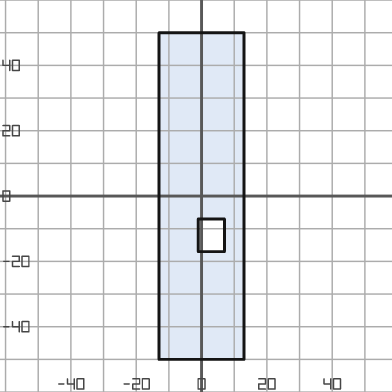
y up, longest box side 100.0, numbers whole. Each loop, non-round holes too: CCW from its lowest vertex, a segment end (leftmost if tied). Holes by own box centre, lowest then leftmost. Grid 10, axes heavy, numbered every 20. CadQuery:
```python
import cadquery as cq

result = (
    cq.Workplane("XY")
    .moveTo(-13.0, -50.0)
    .lineTo(13.0, -50.0)
    .lineTo(13.0, 50.0)
    .lineTo(-13.0, 50.0)
    .close()
    .moveTo(-1.0, -17.0)
    .lineTo(7.0, -17.0)
    .lineTo(7.0, -7.0)
    .lineTo(-1.0, -7.0)
    .close()
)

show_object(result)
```